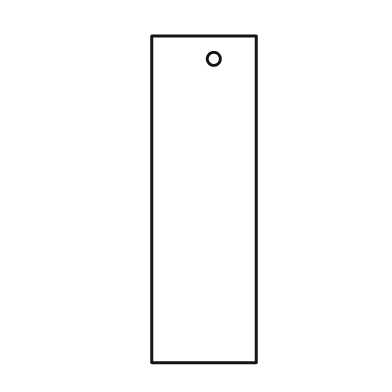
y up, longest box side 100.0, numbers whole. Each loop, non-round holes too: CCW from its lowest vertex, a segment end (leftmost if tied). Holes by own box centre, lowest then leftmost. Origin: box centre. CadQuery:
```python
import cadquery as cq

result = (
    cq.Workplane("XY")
    .moveTo(-16.0, -50.0)
    .lineTo(16.0, -50.0)
    .lineTo(16.0, 50.0)
    .lineTo(-16.0, 50.0)
    .close()
    .moveTo(3.0, 43.0)
    .circle(2.0)
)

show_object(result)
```